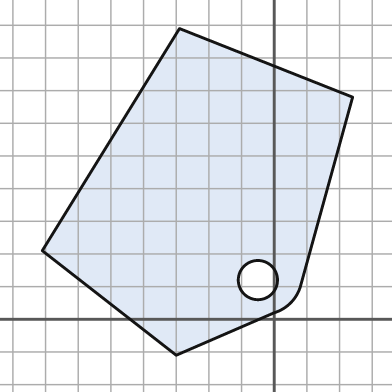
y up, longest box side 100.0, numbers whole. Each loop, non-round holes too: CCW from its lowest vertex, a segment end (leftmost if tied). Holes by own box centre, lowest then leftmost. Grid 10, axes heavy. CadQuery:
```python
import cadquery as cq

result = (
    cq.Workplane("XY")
    .moveTo(-30.0, -11.0)
    .lineTo(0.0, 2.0)
    .threePointArc((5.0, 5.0), (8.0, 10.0))
    .lineTo(24.0, 68.0)
    .lineTo(-29.0, 89.0)
    .lineTo(-71.0, 21.0)
    .close()
    .moveTo(-5.0, 12.0)
    .circle(6.0)
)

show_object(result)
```